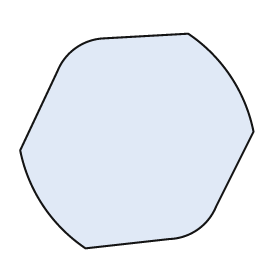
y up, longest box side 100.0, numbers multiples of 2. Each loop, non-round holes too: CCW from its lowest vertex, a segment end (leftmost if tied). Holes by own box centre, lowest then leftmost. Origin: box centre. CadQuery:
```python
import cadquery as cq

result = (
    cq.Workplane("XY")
    .moveTo(-22.0, -46.0)
    .lineTo(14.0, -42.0)
    .threePointArc((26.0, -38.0), (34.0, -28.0))
    .lineTo(50.0, 4.0)
    .threePointArc((40.0, 28.0), (22.0, 46.0))
    .lineTo(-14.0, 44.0)
    .threePointArc((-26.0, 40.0), (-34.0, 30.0))
    .lineTo(-50.0, -4.0)
    .threePointArc((-40.0, -28.0), (-22.0, -46.0))
    .close()
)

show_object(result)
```